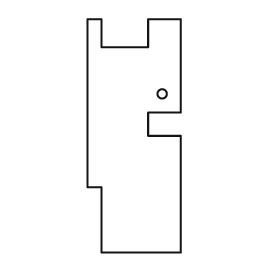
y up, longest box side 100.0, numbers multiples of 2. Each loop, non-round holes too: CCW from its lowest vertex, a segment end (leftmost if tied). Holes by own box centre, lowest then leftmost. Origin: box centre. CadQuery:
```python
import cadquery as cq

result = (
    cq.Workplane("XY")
    .moveTo(-14.0, -50.0)
    .lineTo(20.0, -50.0)
    .lineTo(20.0, 0.0)
    .lineTo(6.0, 0.0)
    .lineTo(6.0, 10.0)
    .lineTo(20.0, 10.0)
    .lineTo(20.0, 50.0)
    .lineTo(6.0, 50.0)
    .lineTo(6.0, 38.0)
    .lineTo(-14.0, 38.0)
    .lineTo(-14.0, 50.0)
    .lineTo(-20.0, 50.0)
    .lineTo(-20.0, -22.0)
    .lineTo(-14.0, -22.0)
    .close()
    .moveTo(12.0, 18.0)
    .circle(2.0)
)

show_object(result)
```